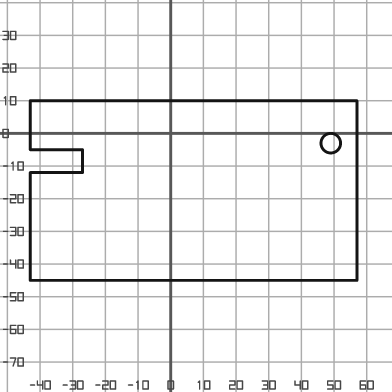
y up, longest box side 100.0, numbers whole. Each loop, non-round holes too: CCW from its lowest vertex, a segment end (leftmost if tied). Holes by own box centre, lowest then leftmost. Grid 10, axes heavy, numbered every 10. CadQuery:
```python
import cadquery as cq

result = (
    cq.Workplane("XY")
    .moveTo(-43.0, -45.0)
    .lineTo(57.0, -45.0)
    .lineTo(57.0, 10.0)
    .lineTo(-43.0, 10.0)
    .lineTo(-43.0, -5.0)
    .lineTo(-27.0, -5.0)
    .lineTo(-27.0, -12.0)
    .lineTo(-43.0, -12.0)
    .close()
    .moveTo(49.0, -3.0)
    .circle(3.0)
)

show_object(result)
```